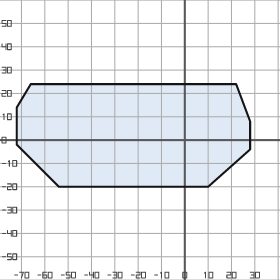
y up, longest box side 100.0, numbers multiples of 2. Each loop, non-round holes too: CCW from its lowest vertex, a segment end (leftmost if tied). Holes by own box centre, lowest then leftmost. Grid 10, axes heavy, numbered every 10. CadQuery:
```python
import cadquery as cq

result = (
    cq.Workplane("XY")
    .moveTo(-54.0, -20.0)
    .lineTo(10.0, -20.0)
    .lineTo(28.0, -4.0)
    .lineTo(28.0, 8.0)
    .lineTo(22.0, 24.0)
    .lineTo(-66.0, 24.0)
    .lineTo(-72.0, 14.0)
    .lineTo(-72.0, -2.0)
    .close()
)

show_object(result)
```